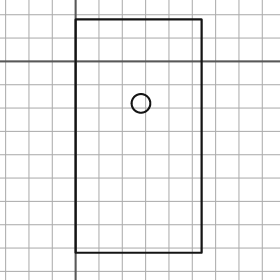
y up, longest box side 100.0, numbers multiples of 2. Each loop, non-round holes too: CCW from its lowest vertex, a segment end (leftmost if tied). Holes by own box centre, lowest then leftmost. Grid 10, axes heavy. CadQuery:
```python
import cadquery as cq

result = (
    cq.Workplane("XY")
    .moveTo(0.0, -82.0)
    .lineTo(54.0, -82.0)
    .lineTo(54.0, 18.0)
    .lineTo(0.0, 18.0)
    .close()
    .moveTo(28.0, -18.0)
    .circle(4.0)
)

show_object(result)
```